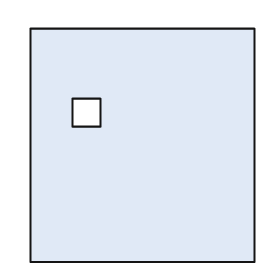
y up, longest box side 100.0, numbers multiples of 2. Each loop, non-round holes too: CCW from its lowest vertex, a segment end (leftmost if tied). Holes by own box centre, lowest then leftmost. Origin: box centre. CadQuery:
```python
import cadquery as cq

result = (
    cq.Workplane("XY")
    .moveTo(-48.0, -50.0)
    .lineTo(48.0, -50.0)
    .lineTo(48.0, 50.0)
    .lineTo(-48.0, 50.0)
    .close()
    .moveTo(-30.0, 8.0)
    .lineTo(-18.0, 8.0)
    .lineTo(-18.0, 20.0)
    .lineTo(-30.0, 20.0)
    .close()
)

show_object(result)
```